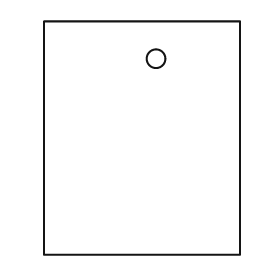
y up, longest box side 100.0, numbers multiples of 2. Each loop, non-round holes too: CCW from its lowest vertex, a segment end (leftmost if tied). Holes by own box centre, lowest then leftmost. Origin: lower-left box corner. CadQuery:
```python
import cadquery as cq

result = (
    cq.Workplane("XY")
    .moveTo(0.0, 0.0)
    .lineTo(84.0, 0.0)
    .lineTo(84.0, 100.0)
    .lineTo(0.0, 100.0)
    .close()
    .moveTo(48.0, 84.0)
    .circle(4.0)
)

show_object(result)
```